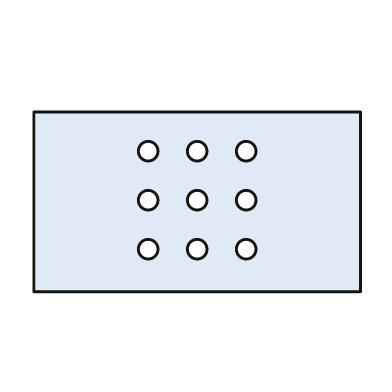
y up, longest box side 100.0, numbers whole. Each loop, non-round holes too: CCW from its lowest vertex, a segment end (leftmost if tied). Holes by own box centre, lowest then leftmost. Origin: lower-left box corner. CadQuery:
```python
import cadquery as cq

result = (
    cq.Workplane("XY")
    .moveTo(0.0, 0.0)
    .lineTo(100.0, 0.0)
    .lineTo(100.0, 55.0)
    .lineTo(0.0, 55.0)
    .close()
    .moveTo(35.0, 13.0)
    .circle(3.0)
    .moveTo(50.0, 13.0)
    .circle(3.0)
    .moveTo(65.0, 13.0)
    .circle(3.0)
    .moveTo(35.0, 28.0)
    .circle(3.0)
    .moveTo(50.0, 28.0)
    .circle(3.0)
    .moveTo(65.0, 28.0)
    .circle(3.0)
    .moveTo(35.0, 43.0)
    .circle(3.0)
    .moveTo(50.0, 43.0)
    .circle(3.0)
    .moveTo(65.0, 43.0)
    .circle(3.0)
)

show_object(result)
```